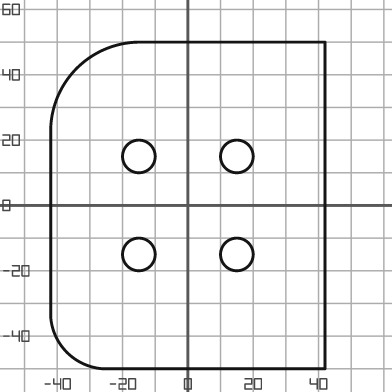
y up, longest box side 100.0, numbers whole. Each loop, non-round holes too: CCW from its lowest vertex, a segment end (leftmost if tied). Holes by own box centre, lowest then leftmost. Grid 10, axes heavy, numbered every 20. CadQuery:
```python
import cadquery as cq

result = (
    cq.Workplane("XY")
    .moveTo(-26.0, -50.0)
    .lineTo(42.0, -50.0)
    .lineTo(42.0, 50.0)
    .lineTo(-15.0, 50.0)
    .threePointArc((-34.0, 42.0), (-42.0, 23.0))
    .lineTo(-42.0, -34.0)
    .threePointArc((-37.0, -45.0), (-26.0, -50.0))
    .close()
    .moveTo(-15.0, -15.0)
    .circle(5.0)
    .moveTo(15.0, -15.0)
    .circle(5.0)
    .moveTo(-15.0, 15.0)
    .circle(5.0)
    .moveTo(15.0, 15.0)
    .circle(5.0)
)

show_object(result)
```